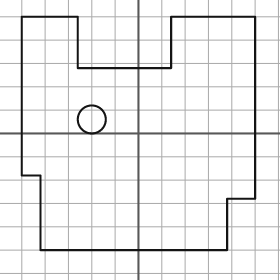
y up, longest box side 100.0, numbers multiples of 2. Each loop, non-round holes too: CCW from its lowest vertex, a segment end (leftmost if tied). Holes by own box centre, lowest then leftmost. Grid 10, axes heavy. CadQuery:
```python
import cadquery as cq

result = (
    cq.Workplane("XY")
    .moveTo(-42.0, -50.0)
    .lineTo(38.0, -50.0)
    .lineTo(38.0, -28.0)
    .lineTo(50.0, -28.0)
    .lineTo(50.0, 50.0)
    .lineTo(14.0, 50.0)
    .lineTo(14.0, 28.0)
    .lineTo(-26.0, 28.0)
    .lineTo(-26.0, 50.0)
    .lineTo(-50.0, 50.0)
    .lineTo(-50.0, -18.0)
    .lineTo(-42.0, -18.0)
    .close()
    .moveTo(-20.0, 6.0)
    .circle(6.0)
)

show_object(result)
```